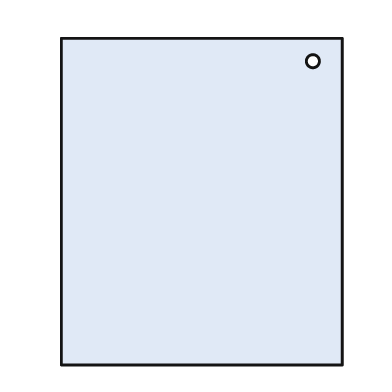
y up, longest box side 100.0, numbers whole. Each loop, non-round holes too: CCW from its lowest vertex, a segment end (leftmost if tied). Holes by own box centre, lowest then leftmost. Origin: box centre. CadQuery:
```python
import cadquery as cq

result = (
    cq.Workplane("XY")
    .moveTo(-43.0, -50.0)
    .lineTo(43.0, -50.0)
    .lineTo(43.0, 50.0)
    .lineTo(-43.0, 50.0)
    .close()
    .moveTo(34.0, 43.0)
    .circle(2.0)
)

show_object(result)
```